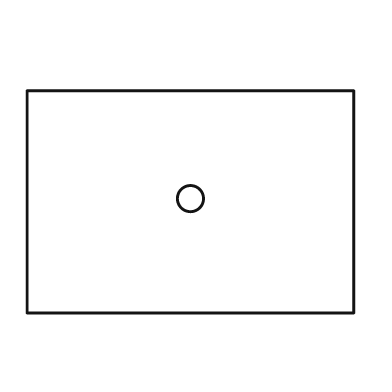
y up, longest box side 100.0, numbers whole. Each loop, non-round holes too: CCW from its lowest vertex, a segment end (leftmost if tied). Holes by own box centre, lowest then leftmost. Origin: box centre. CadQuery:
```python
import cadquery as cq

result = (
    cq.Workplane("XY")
    .moveTo(-50.0, -34.0)
    .lineTo(50.0, -34.0)
    .lineTo(50.0, 34.0)
    .lineTo(-50.0, 34.0)
    .close()
    .moveTo(0.0, 1.0)
    .circle(4.0)
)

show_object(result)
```